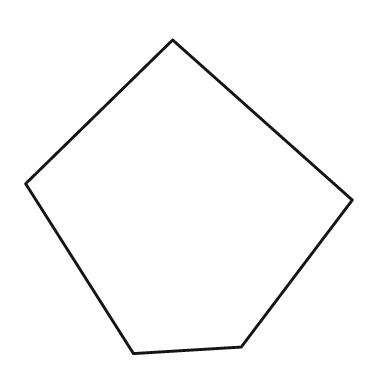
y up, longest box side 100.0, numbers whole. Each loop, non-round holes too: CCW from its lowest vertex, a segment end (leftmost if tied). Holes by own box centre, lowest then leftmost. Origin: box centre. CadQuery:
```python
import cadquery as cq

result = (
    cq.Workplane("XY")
    .moveTo(-17.0, -48.0)
    .lineTo(16.0, -46.0)
    .lineTo(50.0, -1.0)
    .lineTo(-5.0, 48.0)
    .lineTo(-50.0, 4.0)
    .close()
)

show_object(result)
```